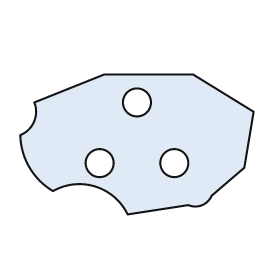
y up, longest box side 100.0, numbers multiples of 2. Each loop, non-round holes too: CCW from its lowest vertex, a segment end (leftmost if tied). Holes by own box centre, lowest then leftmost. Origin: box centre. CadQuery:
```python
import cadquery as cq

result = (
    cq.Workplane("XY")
    .moveTo(-4.0, -30.0)
    .lineTo(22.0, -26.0)
    .threePointArc((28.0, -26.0), (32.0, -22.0))
    .lineTo(46.0, -10.0)
    .lineTo(50.0, 14.0)
    .lineTo(24.0, 30.0)
    .lineTo(-14.0, 30.0)
    .lineTo(-44.0, 18.0)
    .threePointArc((-44.0, 10.0), (-50.0, 4.0))
    .threePointArc((-46.0, -10.0), (-36.0, -20.0))
    .threePointArc((-18.0, -18.0), (-4.0, -30.0))
    .close()
    .moveTo(-16.0, -8.0)
    .circle(6.0)
    .moveTo(16.0, -8.0)
    .circle(6.0)
    .moveTo(0.0, 18.0)
    .circle(6.0)
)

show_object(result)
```